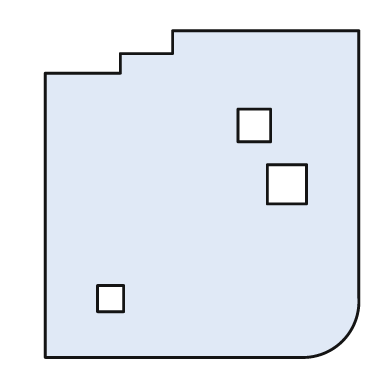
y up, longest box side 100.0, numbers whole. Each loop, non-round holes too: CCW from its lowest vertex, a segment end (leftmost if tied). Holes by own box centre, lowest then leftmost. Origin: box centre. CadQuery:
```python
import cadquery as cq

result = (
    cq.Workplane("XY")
    .moveTo(-48.0, -50.0)
    .lineTo(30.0, -50.0)
    .threePointArc((43.0, -45.0), (48.0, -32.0))
    .lineTo(48.0, 50.0)
    .lineTo(-9.0, 50.0)
    .lineTo(-9.0, 43.0)
    .lineTo(-25.0, 43.0)
    .lineTo(-25.0, 37.0)
    .lineTo(-48.0, 37.0)
    .close()
    .moveTo(-32.0, -36.0)
    .lineTo(-24.0, -36.0)
    .lineTo(-24.0, -28.0)
    .lineTo(-32.0, -28.0)
    .close()
    .moveTo(20.0, -3.0)
    .lineTo(32.0, -3.0)
    .lineTo(32.0, 9.0)
    .lineTo(20.0, 9.0)
    .close()
    .moveTo(11.0, 16.0)
    .lineTo(21.0, 16.0)
    .lineTo(21.0, 26.0)
    .lineTo(11.0, 26.0)
    .close()
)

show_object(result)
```